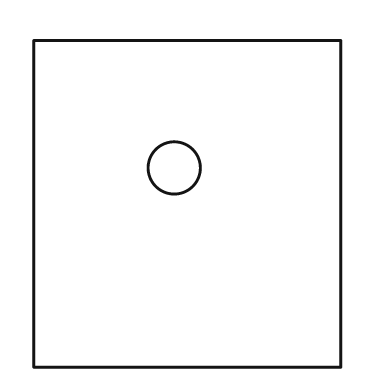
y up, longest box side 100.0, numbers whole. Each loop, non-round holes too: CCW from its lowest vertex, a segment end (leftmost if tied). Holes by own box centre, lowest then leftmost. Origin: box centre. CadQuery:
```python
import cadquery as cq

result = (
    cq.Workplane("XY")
    .moveTo(-47.0, -50.0)
    .lineTo(47.0, -50.0)
    .lineTo(47.0, 50.0)
    .lineTo(-47.0, 50.0)
    .close()
    .moveTo(-4.0, 11.0)
    .circle(8.0)
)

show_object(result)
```